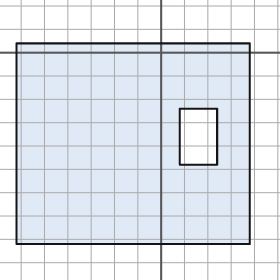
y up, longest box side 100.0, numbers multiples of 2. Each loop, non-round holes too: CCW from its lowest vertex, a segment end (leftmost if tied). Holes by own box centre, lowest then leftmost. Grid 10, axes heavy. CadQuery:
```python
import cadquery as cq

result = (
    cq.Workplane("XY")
    .moveTo(-62.0, -82.0)
    .lineTo(38.0, -82.0)
    .lineTo(38.0, 4.0)
    .lineTo(-62.0, 4.0)
    .close()
    .moveTo(8.0, -48.0)
    .lineTo(24.0, -48.0)
    .lineTo(24.0, -24.0)
    .lineTo(8.0, -24.0)
    .close()
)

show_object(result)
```